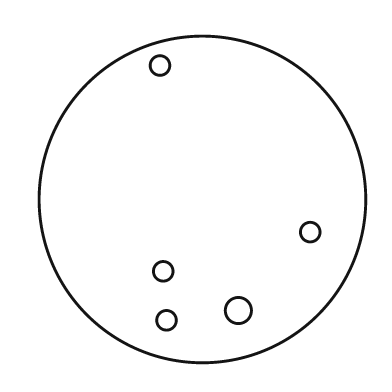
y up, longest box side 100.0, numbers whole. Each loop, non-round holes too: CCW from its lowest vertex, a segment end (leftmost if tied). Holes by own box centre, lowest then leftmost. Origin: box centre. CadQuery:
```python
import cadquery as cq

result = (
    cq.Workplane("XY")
    .moveTo(0.0, 0.0)
    .circle(50.0)
    .moveTo(-11.0, -37.0)
    .circle(3.0)
    .moveTo(11.0, -34.0)
    .circle(4.0)
    .moveTo(-12.0, -22.0)
    .circle(3.0)
    .moveTo(33.0, -10.0)
    .circle(3.0)
    .moveTo(-13.0, 41.0)
    .circle(3.0)
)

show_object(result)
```